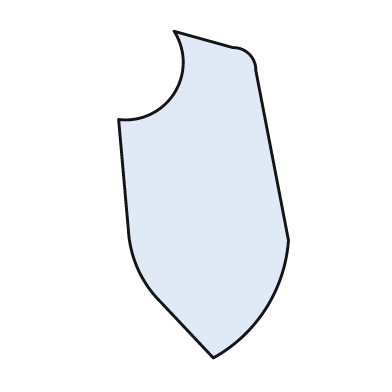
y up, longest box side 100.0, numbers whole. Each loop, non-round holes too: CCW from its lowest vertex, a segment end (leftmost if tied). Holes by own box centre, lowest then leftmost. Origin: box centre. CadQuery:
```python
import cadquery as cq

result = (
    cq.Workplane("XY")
    .moveTo(3.0, -50.0)
    .threePointArc((19.0, -35.0), (26.0, -14.0))
    .lineTo(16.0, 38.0)
    .threePointArc((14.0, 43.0), (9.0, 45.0))
    .lineTo(-9.0, 50.0)
    .threePointArc((-9.0, 31.0), (-26.0, 23.0))
    .lineTo(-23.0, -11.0)
    .threePointArc((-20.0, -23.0), (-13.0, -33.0))
    .close()
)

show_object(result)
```